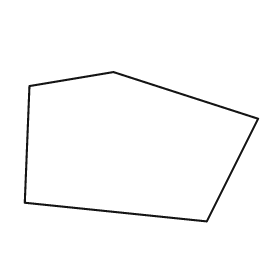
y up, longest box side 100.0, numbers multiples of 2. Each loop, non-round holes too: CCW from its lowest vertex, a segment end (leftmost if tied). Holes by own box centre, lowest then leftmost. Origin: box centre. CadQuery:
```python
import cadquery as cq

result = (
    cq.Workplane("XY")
    .moveTo(28.0, -32.0)
    .lineTo(50.0, 12.0)
    .lineTo(-12.0, 32.0)
    .lineTo(-48.0, 26.0)
    .lineTo(-50.0, -24.0)
    .close()
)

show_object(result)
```